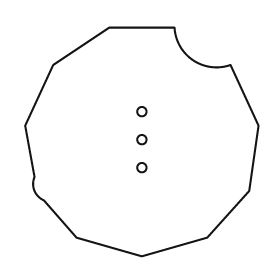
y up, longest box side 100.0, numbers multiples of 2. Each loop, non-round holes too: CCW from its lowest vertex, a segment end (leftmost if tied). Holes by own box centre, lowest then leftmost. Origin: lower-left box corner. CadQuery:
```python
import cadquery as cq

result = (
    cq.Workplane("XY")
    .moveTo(50.0, 0.0)
    .lineTo(78.0, 8.0)
    .lineTo(96.0, 28.0)
    .lineTo(100.0, 56.0)
    .lineTo(88.0, 82.0)
    .threePointArc((72.0, 84.0), (64.0, 98.0))
    .lineTo(36.0, 98.0)
    .lineTo(12.0, 82.0)
    .lineTo(0.0, 56.0)
    .lineTo(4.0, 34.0)
    .threePointArc((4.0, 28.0), (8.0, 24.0))
    .lineTo(22.0, 8.0)
    .close()
    .moveTo(50.0, 38.0)
    .circle(2.0)
    .moveTo(50.0, 50.0)
    .circle(2.0)
    .moveTo(50.0, 62.0)
    .circle(2.0)
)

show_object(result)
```